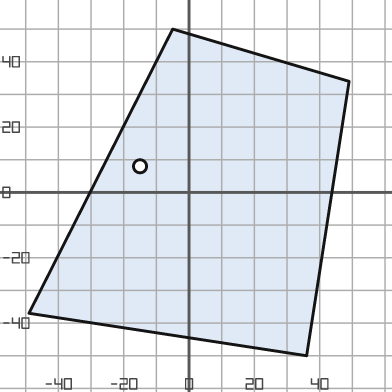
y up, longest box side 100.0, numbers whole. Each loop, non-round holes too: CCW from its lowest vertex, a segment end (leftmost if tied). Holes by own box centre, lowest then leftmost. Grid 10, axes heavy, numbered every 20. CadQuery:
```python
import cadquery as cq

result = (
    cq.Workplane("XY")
    .moveTo(36.0, -50.0)
    .lineTo(49.0, 34.0)
    .lineTo(-5.0, 50.0)
    .lineTo(-49.0, -37.0)
    .close()
    .moveTo(-15.0, 8.0)
    .circle(2.0)
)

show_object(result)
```